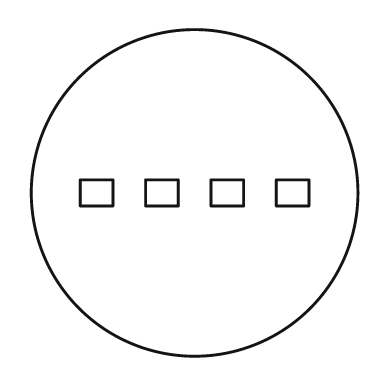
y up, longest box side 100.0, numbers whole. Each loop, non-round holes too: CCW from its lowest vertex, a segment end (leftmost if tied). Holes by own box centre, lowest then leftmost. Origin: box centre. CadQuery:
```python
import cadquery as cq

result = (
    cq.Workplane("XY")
    .moveTo(0.0, 0.0)
    .circle(50.0)
    .moveTo(-35.0, -4.0)
    .lineTo(-25.0, -4.0)
    .lineTo(-25.0, 4.0)
    .lineTo(-35.0, 4.0)
    .close()
    .moveTo(-15.0, -4.0)
    .lineTo(-5.0, -4.0)
    .lineTo(-5.0, 4.0)
    .lineTo(-15.0, 4.0)
    .close()
    .moveTo(5.0, -4.0)
    .lineTo(15.0, -4.0)
    .lineTo(15.0, 4.0)
    .lineTo(5.0, 4.0)
    .close()
    .moveTo(25.0, -4.0)
    .lineTo(35.0, -4.0)
    .lineTo(35.0, 4.0)
    .lineTo(25.0, 4.0)
    .close()
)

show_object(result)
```